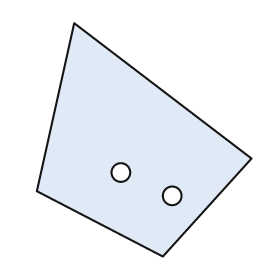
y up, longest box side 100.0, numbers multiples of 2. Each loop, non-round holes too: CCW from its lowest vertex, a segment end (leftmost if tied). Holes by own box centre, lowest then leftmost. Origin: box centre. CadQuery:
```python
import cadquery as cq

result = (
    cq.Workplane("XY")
    .moveTo(8.0, -50.0)
    .lineTo(46.0, -8.0)
    .lineTo(-30.0, 50.0)
    .lineTo(-46.0, -22.0)
    .close()
    .moveTo(12.0, -24.0)
    .circle(4.0)
    .moveTo(-10.0, -14.0)
    .circle(4.0)
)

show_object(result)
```